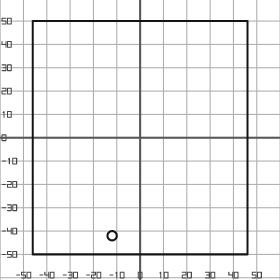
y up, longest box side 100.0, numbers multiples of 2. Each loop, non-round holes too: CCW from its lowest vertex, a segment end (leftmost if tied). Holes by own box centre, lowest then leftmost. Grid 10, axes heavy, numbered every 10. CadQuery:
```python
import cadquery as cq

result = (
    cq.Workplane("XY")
    .moveTo(-46.0, -50.0)
    .lineTo(46.0, -50.0)
    .lineTo(46.0, 50.0)
    .lineTo(-46.0, 50.0)
    .close()
    .moveTo(-12.0, -42.0)
    .circle(2.0)
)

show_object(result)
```